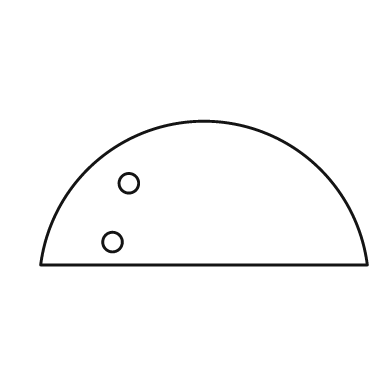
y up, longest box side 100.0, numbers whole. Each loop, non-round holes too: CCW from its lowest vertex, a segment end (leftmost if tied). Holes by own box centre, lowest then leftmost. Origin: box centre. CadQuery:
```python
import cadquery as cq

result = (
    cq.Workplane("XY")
    .moveTo(-50.0, -22.0)
    .lineTo(50.0, -22.0)
    .threePointArc((0.0, 22.0), (-50.0, -22.0))
    .close()
    .moveTo(-28.0, -15.0)
    .circle(3.0)
    .moveTo(-23.0, 3.0)
    .circle(3.0)
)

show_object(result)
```